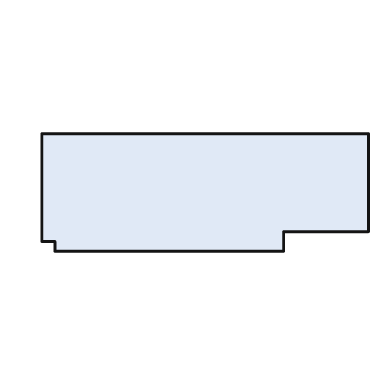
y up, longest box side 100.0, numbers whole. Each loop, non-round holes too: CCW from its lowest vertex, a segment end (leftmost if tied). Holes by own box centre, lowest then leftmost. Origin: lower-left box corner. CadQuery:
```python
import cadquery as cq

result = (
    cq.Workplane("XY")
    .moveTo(4.0, 0.0)
    .lineTo(74.0, 0.0)
    .lineTo(74.0, 6.0)
    .lineTo(100.0, 6.0)
    .lineTo(100.0, 36.0)
    .lineTo(0.0, 36.0)
    .lineTo(0.0, 3.0)
    .lineTo(4.0, 3.0)
    .close()
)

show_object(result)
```